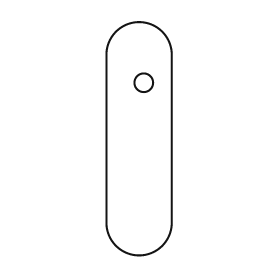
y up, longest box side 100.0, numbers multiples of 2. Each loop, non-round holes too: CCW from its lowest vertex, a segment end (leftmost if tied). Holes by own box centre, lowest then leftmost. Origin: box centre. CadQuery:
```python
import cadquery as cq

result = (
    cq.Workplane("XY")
    .moveTo(-14.0, -36.0)
    .threePointArc((0.0, -50.0), (14.0, -36.0))
    .lineTo(14.0, 36.0)
    .threePointArc((0.0, 50.0), (-14.0, 36.0))
    .close()
    .moveTo(2.0, 24.0)
    .circle(4.0)
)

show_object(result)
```